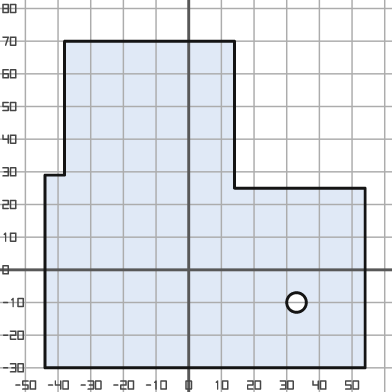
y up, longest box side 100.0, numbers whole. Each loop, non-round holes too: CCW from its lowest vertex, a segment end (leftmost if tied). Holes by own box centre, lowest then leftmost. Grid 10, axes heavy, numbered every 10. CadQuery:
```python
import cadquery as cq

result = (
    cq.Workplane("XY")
    .moveTo(-44.0, -30.0)
    .lineTo(54.0, -30.0)
    .lineTo(54.0, 25.0)
    .lineTo(14.0, 25.0)
    .lineTo(14.0, 70.0)
    .lineTo(-38.0, 70.0)
    .lineTo(-38.0, 29.0)
    .lineTo(-44.0, 29.0)
    .close()
    .moveTo(33.0, -10.0)
    .circle(3.0)
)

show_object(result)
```